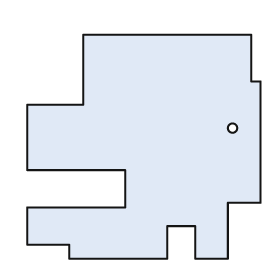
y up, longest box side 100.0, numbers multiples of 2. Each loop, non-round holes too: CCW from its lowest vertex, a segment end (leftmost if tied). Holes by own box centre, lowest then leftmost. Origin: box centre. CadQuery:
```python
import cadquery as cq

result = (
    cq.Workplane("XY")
    .moveTo(-32.0, -48.0)
    .lineTo(10.0, -48.0)
    .lineTo(10.0, -34.0)
    .lineTo(22.0, -34.0)
    .lineTo(22.0, -48.0)
    .lineTo(36.0, -48.0)
    .lineTo(36.0, -24.0)
    .lineTo(50.0, -24.0)
    .lineTo(50.0, 28.0)
    .lineTo(46.0, 28.0)
    .lineTo(46.0, 48.0)
    .lineTo(-26.0, 48.0)
    .lineTo(-26.0, 18.0)
    .lineTo(-50.0, 18.0)
    .lineTo(-50.0, -10.0)
    .lineTo(-8.0, -10.0)
    .lineTo(-8.0, -26.0)
    .lineTo(-50.0, -26.0)
    .lineTo(-50.0, -42.0)
    .lineTo(-32.0, -42.0)
    .close()
    .moveTo(38.0, 8.0)
    .circle(2.0)
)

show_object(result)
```